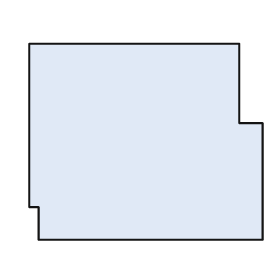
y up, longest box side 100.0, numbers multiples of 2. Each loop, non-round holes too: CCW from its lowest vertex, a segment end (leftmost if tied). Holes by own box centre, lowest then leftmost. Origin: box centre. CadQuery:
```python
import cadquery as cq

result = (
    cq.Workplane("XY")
    .moveTo(-46.0, -42.0)
    .lineTo(50.0, -42.0)
    .lineTo(50.0, 8.0)
    .lineTo(40.0, 8.0)
    .lineTo(40.0, 42.0)
    .lineTo(-50.0, 42.0)
    .lineTo(-50.0, -28.0)
    .lineTo(-46.0, -28.0)
    .close()
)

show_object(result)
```